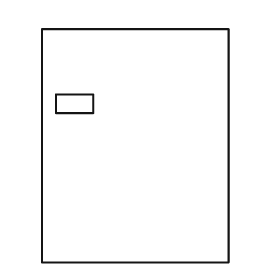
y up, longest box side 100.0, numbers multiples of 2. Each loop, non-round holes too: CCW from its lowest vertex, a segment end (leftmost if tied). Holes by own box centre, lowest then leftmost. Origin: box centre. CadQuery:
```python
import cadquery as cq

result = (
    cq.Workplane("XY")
    .moveTo(-40.0, -50.0)
    .lineTo(40.0, -50.0)
    .lineTo(40.0, 50.0)
    .lineTo(-40.0, 50.0)
    .close()
    .moveTo(-34.0, 14.0)
    .lineTo(-18.0, 14.0)
    .lineTo(-18.0, 22.0)
    .lineTo(-34.0, 22.0)
    .close()
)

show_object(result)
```